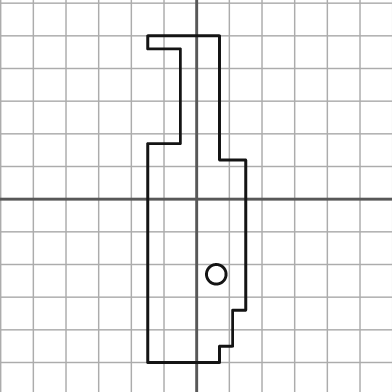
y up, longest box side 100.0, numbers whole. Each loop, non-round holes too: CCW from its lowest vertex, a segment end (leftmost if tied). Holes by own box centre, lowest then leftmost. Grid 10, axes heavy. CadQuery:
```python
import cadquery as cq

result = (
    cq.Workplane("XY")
    .moveTo(-15.0, -50.0)
    .lineTo(7.0, -50.0)
    .lineTo(7.0, -45.0)
    .lineTo(11.0, -45.0)
    .lineTo(11.0, -34.0)
    .lineTo(15.0, -34.0)
    .lineTo(15.0, 12.0)
    .lineTo(7.0, 12.0)
    .lineTo(7.0, 50.0)
    .lineTo(-15.0, 50.0)
    .lineTo(-15.0, 46.0)
    .lineTo(-5.0, 46.0)
    .lineTo(-5.0, 17.0)
    .lineTo(-15.0, 17.0)
    .close()
    .moveTo(6.0, -23.0)
    .circle(3.0)
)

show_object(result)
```